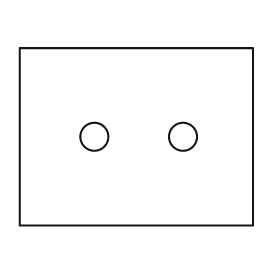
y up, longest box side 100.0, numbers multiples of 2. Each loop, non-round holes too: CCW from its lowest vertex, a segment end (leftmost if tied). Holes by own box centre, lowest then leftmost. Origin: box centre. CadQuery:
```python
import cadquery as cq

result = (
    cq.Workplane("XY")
    .moveTo(-50.0, -38.0)
    .lineTo(50.0, -38.0)
    .lineTo(50.0, 38.0)
    .lineTo(-50.0, 38.0)
    .close()
    .moveTo(-18.0, 0.0)
    .circle(6.0)
    .moveTo(20.0, 0.0)
    .circle(6.0)
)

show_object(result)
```